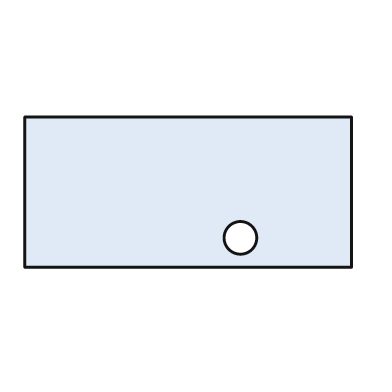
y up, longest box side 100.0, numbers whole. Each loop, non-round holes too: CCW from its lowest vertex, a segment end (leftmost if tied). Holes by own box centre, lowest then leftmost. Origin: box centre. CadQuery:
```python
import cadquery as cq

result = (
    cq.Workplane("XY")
    .moveTo(-50.0, -23.0)
    .lineTo(50.0, -23.0)
    .lineTo(50.0, 23.0)
    .lineTo(-50.0, 23.0)
    .close()
    .moveTo(16.0, -14.0)
    .circle(5.0)
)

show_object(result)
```